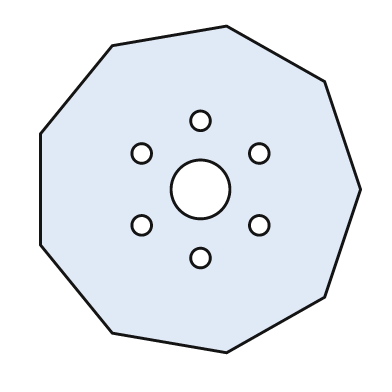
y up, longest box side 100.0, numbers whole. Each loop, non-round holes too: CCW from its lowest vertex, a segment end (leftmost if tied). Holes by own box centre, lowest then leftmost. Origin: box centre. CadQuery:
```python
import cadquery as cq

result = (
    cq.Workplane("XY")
    .moveTo(8.0, -50.0)
    .lineTo(38.0, -33.0)
    .lineTo(49.0, 0.0)
    .lineTo(38.0, 33.0)
    .lineTo(8.0, 50.0)
    .lineTo(-27.0, 44.0)
    .lineTo(-49.0, 17.0)
    .lineTo(-49.0, -17.0)
    .lineTo(-27.0, -44.0)
    .close()
    .moveTo(0.0, -21.0)
    .circle(3.0)
    .moveTo(-18.0, -11.0)
    .circle(3.0)
    .moveTo(18.0, -11.0)
    .circle(3.0)
    .moveTo(0.0, 0.0)
    .circle(9.0)
    .moveTo(-18.0, 11.0)
    .circle(3.0)
    .moveTo(18.0, 11.0)
    .circle(3.0)
    .moveTo(0.0, 21.0)
    .circle(3.0)
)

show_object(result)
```